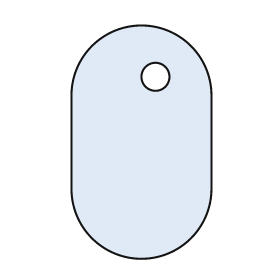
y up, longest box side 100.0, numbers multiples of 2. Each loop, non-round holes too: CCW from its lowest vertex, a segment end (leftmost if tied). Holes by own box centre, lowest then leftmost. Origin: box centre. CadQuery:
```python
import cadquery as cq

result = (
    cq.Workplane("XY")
    .moveTo(-30.0, -20.0)
    .threePointArc((0.0, -50.0), (30.0, -20.0))
    .lineTo(30.0, 20.0)
    .threePointArc((0.0, 50.0), (-30.0, 20.0))
    .close()
    .moveTo(6.0, 28.0)
    .circle(6.0)
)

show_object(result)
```